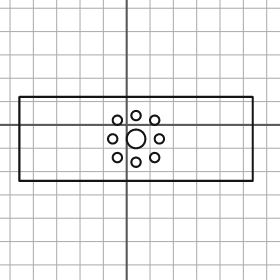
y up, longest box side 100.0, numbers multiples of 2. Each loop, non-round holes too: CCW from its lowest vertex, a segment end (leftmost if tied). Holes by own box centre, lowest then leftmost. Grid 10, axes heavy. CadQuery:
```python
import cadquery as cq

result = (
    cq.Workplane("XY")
    .moveTo(-46.0, -24.0)
    .lineTo(54.0, -24.0)
    .lineTo(54.0, 12.0)
    .lineTo(-46.0, 12.0)
    .close()
    .moveTo(4.0, -16.0)
    .circle(2.0)
    .moveTo(-4.0, -14.0)
    .circle(2.0)
    .moveTo(12.0, -14.0)
    .circle(2.0)
    .moveTo(-6.0, -6.0)
    .circle(2.0)
    .moveTo(4.0, -6.0)
    .circle(4.0)
    .moveTo(14.0, -6.0)
    .circle(2.0)
    .moveTo(-4.0, 2.0)
    .circle(2.0)
    .moveTo(12.0, 2.0)
    .circle(2.0)
    .moveTo(4.0, 4.0)
    .circle(2.0)
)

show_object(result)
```